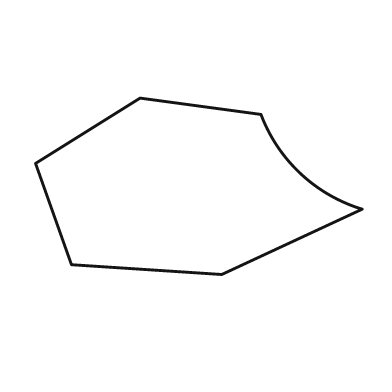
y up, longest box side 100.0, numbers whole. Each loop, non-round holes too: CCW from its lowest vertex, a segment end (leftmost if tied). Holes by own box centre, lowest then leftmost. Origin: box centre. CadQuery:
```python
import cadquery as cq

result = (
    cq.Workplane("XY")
    .moveTo(7.0, -27.0)
    .lineTo(50.0, -7.0)
    .threePointArc((31.0, 4.0), (19.0, 22.0))
    .lineTo(-18.0, 27.0)
    .lineTo(-50.0, 7.0)
    .lineTo(-39.0, -24.0)
    .close()
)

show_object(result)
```